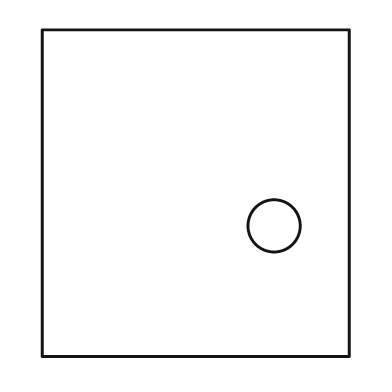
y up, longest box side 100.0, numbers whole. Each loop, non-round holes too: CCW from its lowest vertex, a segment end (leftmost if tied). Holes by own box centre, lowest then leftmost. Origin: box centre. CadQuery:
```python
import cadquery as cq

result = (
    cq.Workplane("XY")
    .moveTo(-47.0, -50.0)
    .lineTo(47.0, -50.0)
    .lineTo(47.0, 50.0)
    .lineTo(-47.0, 50.0)
    .close()
    .moveTo(24.0, -10.0)
    .circle(8.0)
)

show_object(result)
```